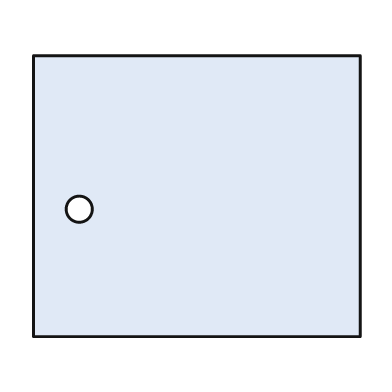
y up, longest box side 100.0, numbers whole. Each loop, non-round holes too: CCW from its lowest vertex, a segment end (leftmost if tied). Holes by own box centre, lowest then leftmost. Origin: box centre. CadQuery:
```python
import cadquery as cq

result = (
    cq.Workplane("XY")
    .moveTo(-50.0, -43.0)
    .lineTo(50.0, -43.0)
    .lineTo(50.0, 43.0)
    .lineTo(-50.0, 43.0)
    .close()
    .moveTo(-36.0, -4.0)
    .circle(4.0)
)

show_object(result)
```